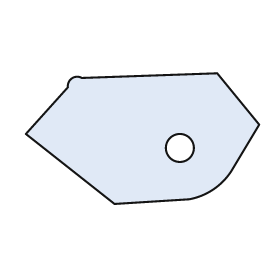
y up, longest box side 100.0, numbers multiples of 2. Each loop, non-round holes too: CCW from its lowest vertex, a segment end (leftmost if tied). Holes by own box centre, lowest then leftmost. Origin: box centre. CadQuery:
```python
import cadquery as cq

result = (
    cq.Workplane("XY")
    .moveTo(-12.0, -28.0)
    .lineTo(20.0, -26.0)
    .threePointArc((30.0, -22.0), (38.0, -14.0))
    .lineTo(50.0, 6.0)
    .lineTo(32.0, 28.0)
    .lineTo(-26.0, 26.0)
    .threePointArc((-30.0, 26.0), (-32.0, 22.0))
    .lineTo(-50.0, 2.0)
    .close()
    .moveTo(16.0, -4.0)
    .circle(6.0)
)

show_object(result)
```